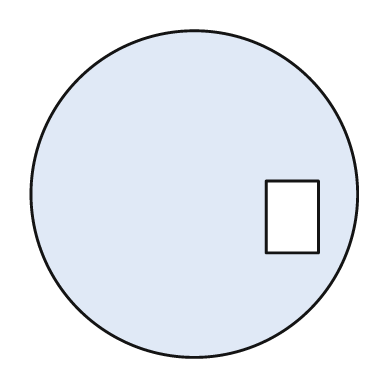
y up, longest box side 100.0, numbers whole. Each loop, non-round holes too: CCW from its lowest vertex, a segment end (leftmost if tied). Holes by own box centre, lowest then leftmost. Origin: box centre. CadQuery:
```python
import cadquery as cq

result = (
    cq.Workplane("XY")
    .moveTo(0.0, 0.0)
    .circle(50.0)
    .moveTo(22.0, -18.0)
    .lineTo(38.0, -18.0)
    .lineTo(38.0, 4.0)
    .lineTo(22.0, 4.0)
    .close()
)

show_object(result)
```